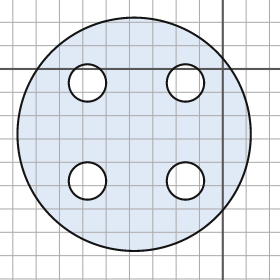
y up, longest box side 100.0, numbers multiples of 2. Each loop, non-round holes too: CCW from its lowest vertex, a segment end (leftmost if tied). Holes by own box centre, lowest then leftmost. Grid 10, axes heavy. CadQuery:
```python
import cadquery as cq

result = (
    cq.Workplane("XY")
    .moveTo(-38.0, -28.0)
    .circle(50.0)
    .moveTo(-58.0, -48.0)
    .circle(8.0)
    .moveTo(-16.0, -48.0)
    .circle(8.0)
    .moveTo(-58.0, -6.0)
    .circle(8.0)
    .moveTo(-16.0, -6.0)
    .circle(8.0)
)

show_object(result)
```